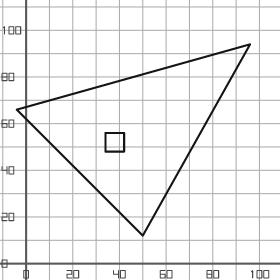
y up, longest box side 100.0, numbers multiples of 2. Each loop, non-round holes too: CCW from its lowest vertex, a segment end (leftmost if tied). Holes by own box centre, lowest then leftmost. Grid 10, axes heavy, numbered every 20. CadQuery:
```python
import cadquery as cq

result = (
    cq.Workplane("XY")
    .moveTo(50.0, 12.0)
    .lineTo(96.0, 94.0)
    .lineTo(-4.0, 66.0)
    .close()
    .moveTo(34.0, 48.0)
    .lineTo(42.0, 48.0)
    .lineTo(42.0, 56.0)
    .lineTo(34.0, 56.0)
    .close()
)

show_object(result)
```